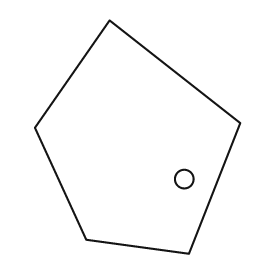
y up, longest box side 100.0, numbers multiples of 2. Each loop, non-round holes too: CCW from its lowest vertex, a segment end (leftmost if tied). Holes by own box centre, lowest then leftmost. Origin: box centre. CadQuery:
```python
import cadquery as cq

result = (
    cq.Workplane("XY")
    .moveTo(22.0, -50.0)
    .lineTo(44.0, 6.0)
    .lineTo(-12.0, 50.0)
    .lineTo(-44.0, 4.0)
    .lineTo(-22.0, -44.0)
    .close()
    .moveTo(20.0, -18.0)
    .circle(4.0)
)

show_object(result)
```